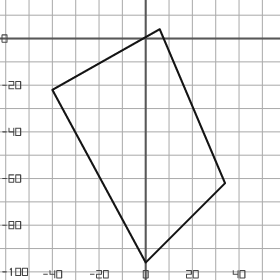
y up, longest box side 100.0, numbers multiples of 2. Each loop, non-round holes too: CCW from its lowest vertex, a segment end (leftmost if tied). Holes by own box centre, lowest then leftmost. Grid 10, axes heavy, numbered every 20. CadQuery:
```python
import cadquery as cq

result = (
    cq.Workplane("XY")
    .moveTo(0.0, -96.0)
    .lineTo(34.0, -62.0)
    .lineTo(6.0, 4.0)
    .lineTo(-40.0, -22.0)
    .close()
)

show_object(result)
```